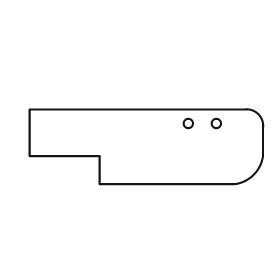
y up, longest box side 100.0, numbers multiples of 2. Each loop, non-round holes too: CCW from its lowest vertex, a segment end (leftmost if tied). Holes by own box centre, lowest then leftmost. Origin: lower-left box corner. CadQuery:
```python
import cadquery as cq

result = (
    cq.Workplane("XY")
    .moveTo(30.0, 0.0)
    .lineTo(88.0, 0.0)
    .threePointArc((96.0, 4.0), (100.0, 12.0))
    .lineTo(100.0, 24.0)
    .threePointArc((98.0, 30.0), (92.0, 32.0))
    .lineTo(0.0, 32.0)
    .lineTo(0.0, 12.0)
    .lineTo(30.0, 12.0)
    .close()
    .moveTo(68.0, 26.0)
    .circle(2.0)
    .moveTo(80.0, 26.0)
    .circle(2.0)
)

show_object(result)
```